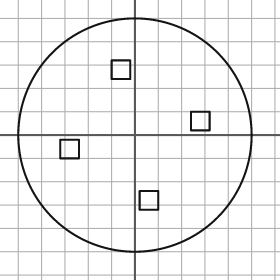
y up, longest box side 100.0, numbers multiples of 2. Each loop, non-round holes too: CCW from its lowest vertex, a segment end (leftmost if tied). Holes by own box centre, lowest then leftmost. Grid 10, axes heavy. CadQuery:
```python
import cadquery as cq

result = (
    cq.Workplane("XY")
    .moveTo(0.0, 0.0)
    .circle(50.0)
    .moveTo(2.0, -32.0)
    .lineTo(10.0, -32.0)
    .lineTo(10.0, -24.0)
    .lineTo(2.0, -24.0)
    .close()
    .moveTo(-32.0, -10.0)
    .lineTo(-24.0, -10.0)
    .lineTo(-24.0, -2.0)
    .lineTo(-32.0, -2.0)
    .close()
    .moveTo(24.0, 2.0)
    .lineTo(32.0, 2.0)
    .lineTo(32.0, 10.0)
    .lineTo(24.0, 10.0)
    .close()
    .moveTo(-10.0, 24.0)
    .lineTo(-2.0, 24.0)
    .lineTo(-2.0, 32.0)
    .lineTo(-10.0, 32.0)
    .close()
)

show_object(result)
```